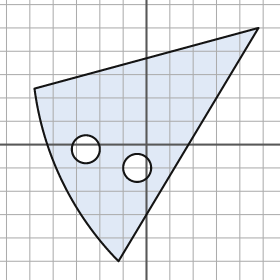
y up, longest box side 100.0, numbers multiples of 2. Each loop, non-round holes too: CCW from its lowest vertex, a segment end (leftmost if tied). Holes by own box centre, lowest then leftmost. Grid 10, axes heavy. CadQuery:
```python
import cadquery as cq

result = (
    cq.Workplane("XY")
    .moveTo(-12.0, -50.0)
    .lineTo(48.0, 50.0)
    .lineTo(-48.0, 24.0)
    .threePointArc((-36.0, -16.0), (-12.0, -50.0))
    .close()
    .moveTo(-4.0, -10.0)
    .circle(6.0)
    .moveTo(-26.0, -2.0)
    .circle(6.0)
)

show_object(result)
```